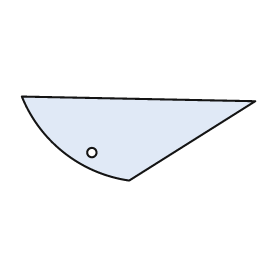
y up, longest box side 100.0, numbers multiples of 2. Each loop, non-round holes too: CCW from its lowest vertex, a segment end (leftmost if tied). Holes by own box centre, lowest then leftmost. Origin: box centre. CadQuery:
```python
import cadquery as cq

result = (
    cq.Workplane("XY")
    .moveTo(-4.0, -18.0)
    .lineTo(50.0, 16.0)
    .lineTo(-50.0, 18.0)
    .threePointArc((-32.0, -6.0), (-4.0, -18.0))
    .close()
    .moveTo(-20.0, -6.0)
    .circle(2.0)
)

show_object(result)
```